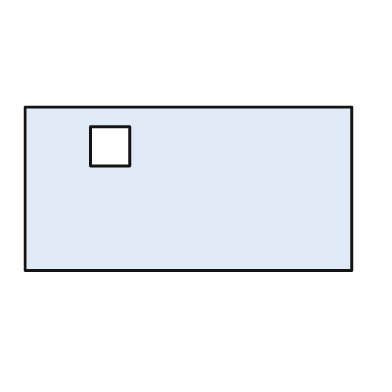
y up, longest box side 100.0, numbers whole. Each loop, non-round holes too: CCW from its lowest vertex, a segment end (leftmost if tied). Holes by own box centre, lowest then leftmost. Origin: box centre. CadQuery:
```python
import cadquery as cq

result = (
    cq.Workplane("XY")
    .moveTo(-50.0, -25.0)
    .lineTo(50.0, -25.0)
    .lineTo(50.0, 25.0)
    .lineTo(-50.0, 25.0)
    .close()
    .moveTo(-30.0, 7.0)
    .lineTo(-18.0, 7.0)
    .lineTo(-18.0, 19.0)
    .lineTo(-30.0, 19.0)
    .close()
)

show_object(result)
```